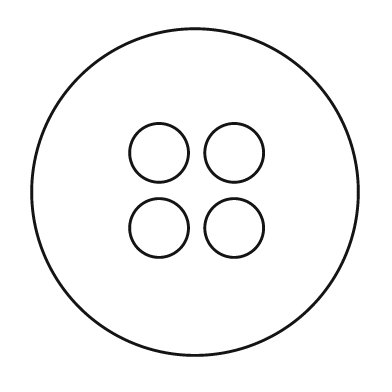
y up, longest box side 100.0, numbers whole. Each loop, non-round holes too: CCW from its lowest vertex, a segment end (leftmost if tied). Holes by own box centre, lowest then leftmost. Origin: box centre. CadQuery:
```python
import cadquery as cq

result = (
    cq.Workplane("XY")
    .moveTo(0.0, 0.0)
    .circle(50.0)
    .moveTo(-11.0, -11.0)
    .circle(9.0)
    .moveTo(12.0, -11.0)
    .circle(9.0)
    .moveTo(-11.0, 12.0)
    .circle(9.0)
    .moveTo(12.0, 12.0)
    .circle(9.0)
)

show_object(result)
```